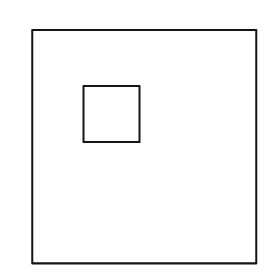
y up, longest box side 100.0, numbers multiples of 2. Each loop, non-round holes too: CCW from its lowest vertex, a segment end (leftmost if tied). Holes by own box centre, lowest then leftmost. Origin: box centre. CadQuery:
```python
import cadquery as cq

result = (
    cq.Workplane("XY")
    .moveTo(-48.0, -50.0)
    .lineTo(48.0, -50.0)
    .lineTo(48.0, 50.0)
    .lineTo(-48.0, 50.0)
    .close()
    .moveTo(-26.0, 2.0)
    .lineTo(-2.0, 2.0)
    .lineTo(-2.0, 26.0)
    .lineTo(-26.0, 26.0)
    .close()
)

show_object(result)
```